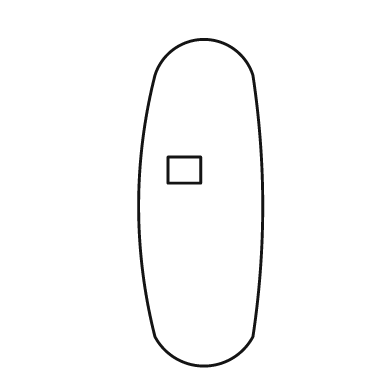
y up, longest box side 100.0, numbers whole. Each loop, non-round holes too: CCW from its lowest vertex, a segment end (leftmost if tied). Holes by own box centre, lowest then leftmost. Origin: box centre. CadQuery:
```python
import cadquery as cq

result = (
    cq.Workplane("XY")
    .moveTo(-14.0, -41.0)
    .threePointArc((1.0, -50.0), (16.0, -41.0))
    .threePointArc((19.0, -1.0), (16.0, 39.0))
    .threePointArc((1.0, 50.0), (-14.0, 39.0))
    .threePointArc((-19.0, -1.0), (-14.0, -41.0))
    .close()
    .moveTo(-10.0, 6.0)
    .lineTo(0.0, 6.0)
    .lineTo(0.0, 14.0)
    .lineTo(-10.0, 14.0)
    .close()
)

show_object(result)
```